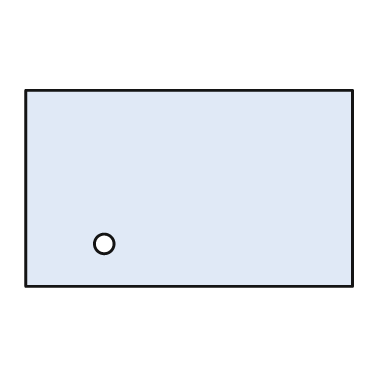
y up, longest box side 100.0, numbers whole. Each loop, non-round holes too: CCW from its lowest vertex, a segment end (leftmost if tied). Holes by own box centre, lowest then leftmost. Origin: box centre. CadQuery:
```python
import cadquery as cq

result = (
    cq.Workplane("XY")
    .moveTo(-50.0, -30.0)
    .lineTo(50.0, -30.0)
    .lineTo(50.0, 30.0)
    .lineTo(-50.0, 30.0)
    .close()
    .moveTo(-26.0, -17.0)
    .circle(3.0)
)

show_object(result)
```